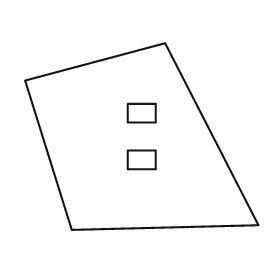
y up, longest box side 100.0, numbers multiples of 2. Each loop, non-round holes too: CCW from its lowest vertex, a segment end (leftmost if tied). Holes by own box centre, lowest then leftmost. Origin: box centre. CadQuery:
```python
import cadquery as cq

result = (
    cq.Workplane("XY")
    .moveTo(-30.0, -40.0)
    .lineTo(50.0, -38.0)
    .lineTo(10.0, 40.0)
    .lineTo(-50.0, 24.0)
    .close()
    .moveTo(-6.0, -14.0)
    .lineTo(6.0, -14.0)
    .lineTo(6.0, -6.0)
    .lineTo(-6.0, -6.0)
    .close()
    .moveTo(-6.0, 6.0)
    .lineTo(6.0, 6.0)
    .lineTo(6.0, 14.0)
    .lineTo(-6.0, 14.0)
    .close()
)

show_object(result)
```